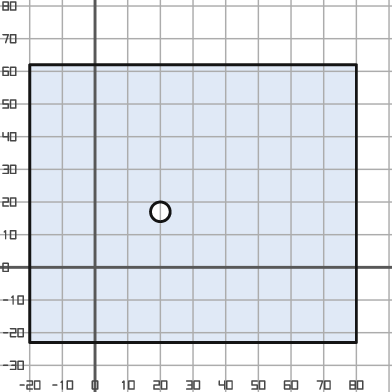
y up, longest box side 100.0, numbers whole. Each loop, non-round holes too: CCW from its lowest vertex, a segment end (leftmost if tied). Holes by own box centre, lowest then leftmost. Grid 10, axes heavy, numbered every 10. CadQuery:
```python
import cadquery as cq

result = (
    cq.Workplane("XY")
    .moveTo(-20.0, -23.0)
    .lineTo(80.0, -23.0)
    .lineTo(80.0, 62.0)
    .lineTo(-20.0, 62.0)
    .close()
    .moveTo(20.0, 17.0)
    .circle(3.0)
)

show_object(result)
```